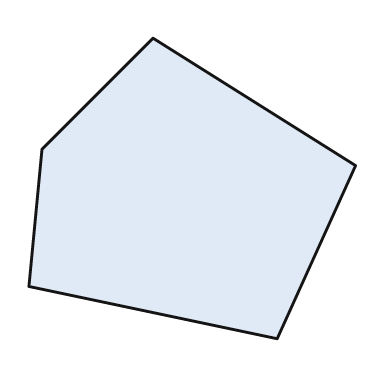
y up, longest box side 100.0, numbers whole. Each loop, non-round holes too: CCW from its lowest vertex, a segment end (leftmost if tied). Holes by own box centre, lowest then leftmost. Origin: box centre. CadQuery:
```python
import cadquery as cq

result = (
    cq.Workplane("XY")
    .moveTo(26.0, -46.0)
    .lineTo(50.0, 7.0)
    .lineTo(-12.0, 46.0)
    .lineTo(-46.0, 12.0)
    .lineTo(-50.0, -30.0)
    .close()
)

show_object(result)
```